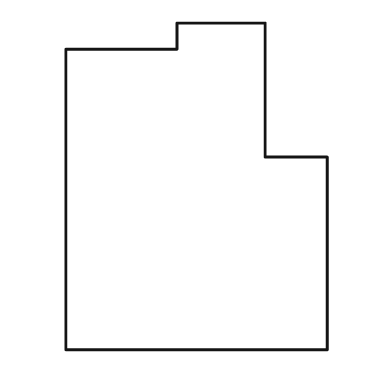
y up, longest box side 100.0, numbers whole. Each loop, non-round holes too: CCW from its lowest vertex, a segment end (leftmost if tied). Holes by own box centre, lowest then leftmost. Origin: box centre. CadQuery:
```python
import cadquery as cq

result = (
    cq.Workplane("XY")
    .moveTo(-40.0, -50.0)
    .lineTo(40.0, -50.0)
    .lineTo(40.0, 9.0)
    .lineTo(21.0, 9.0)
    .lineTo(21.0, 50.0)
    .lineTo(-6.0, 50.0)
    .lineTo(-6.0, 42.0)
    .lineTo(-40.0, 42.0)
    .close()
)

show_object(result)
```